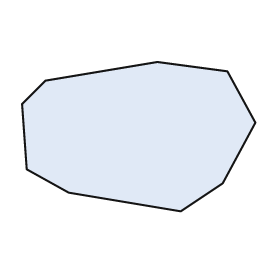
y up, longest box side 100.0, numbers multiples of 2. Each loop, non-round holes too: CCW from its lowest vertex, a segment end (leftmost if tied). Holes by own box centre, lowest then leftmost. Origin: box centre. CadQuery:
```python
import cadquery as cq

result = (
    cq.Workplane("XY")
    .moveTo(18.0, -32.0)
    .lineTo(36.0, -20.0)
    .lineTo(50.0, 6.0)
    .lineTo(38.0, 28.0)
    .lineTo(8.0, 32.0)
    .lineTo(-40.0, 24.0)
    .lineTo(-50.0, 14.0)
    .lineTo(-48.0, -14.0)
    .lineTo(-30.0, -24.0)
    .close()
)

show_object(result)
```